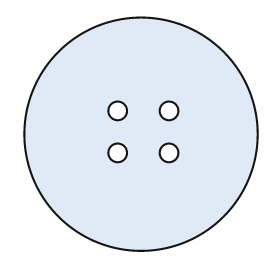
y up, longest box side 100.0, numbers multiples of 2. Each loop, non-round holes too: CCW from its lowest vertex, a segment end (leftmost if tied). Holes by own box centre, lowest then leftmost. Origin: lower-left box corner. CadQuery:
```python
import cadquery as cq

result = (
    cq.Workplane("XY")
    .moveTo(50.0, 50.0)
    .circle(50.0)
    .moveTo(40.0, 42.0)
    .circle(4.0)
    .moveTo(62.0, 42.0)
    .circle(4.0)
    .moveTo(40.0, 60.0)
    .circle(4.0)
    .moveTo(62.0, 60.0)
    .circle(4.0)
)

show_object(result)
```